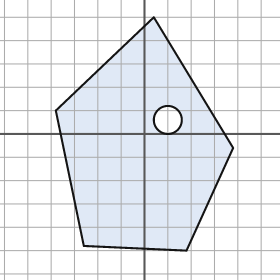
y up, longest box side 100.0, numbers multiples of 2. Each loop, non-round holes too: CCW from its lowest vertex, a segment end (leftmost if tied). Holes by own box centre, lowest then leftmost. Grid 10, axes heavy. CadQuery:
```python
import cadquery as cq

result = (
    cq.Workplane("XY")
    .moveTo(18.0, -50.0)
    .lineTo(38.0, -6.0)
    .lineTo(4.0, 50.0)
    .lineTo(-38.0, 10.0)
    .lineTo(-26.0, -48.0)
    .close()
    .moveTo(10.0, 6.0)
    .circle(6.0)
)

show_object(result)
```